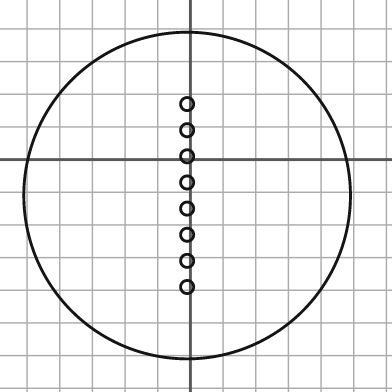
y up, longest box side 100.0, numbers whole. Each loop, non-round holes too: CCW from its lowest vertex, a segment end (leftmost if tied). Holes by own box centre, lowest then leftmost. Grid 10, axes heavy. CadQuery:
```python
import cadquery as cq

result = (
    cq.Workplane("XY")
    .moveTo(-1.0, -11.0)
    .circle(50.0)
    .moveTo(-1.0, -39.0)
    .circle(2.0)
    .moveTo(-1.0, -31.0)
    .circle(2.0)
    .moveTo(-1.0, -23.0)
    .circle(2.0)
    .moveTo(-1.0, -15.0)
    .circle(2.0)
    .moveTo(-1.0, -7.0)
    .circle(2.0)
    .moveTo(-1.0, 1.0)
    .circle(2.0)
    .moveTo(-1.0, 9.0)
    .circle(2.0)
    .moveTo(-1.0, 17.0)
    .circle(2.0)
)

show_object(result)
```